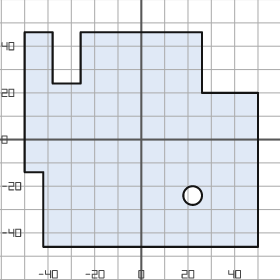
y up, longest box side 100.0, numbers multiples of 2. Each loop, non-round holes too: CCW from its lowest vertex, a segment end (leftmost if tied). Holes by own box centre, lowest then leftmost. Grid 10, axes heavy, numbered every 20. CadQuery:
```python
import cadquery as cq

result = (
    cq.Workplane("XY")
    .moveTo(-42.0, -46.0)
    .lineTo(50.0, -46.0)
    .lineTo(50.0, 20.0)
    .lineTo(26.0, 20.0)
    .lineTo(26.0, 46.0)
    .lineTo(-26.0, 46.0)
    .lineTo(-26.0, 24.0)
    .lineTo(-38.0, 24.0)
    .lineTo(-38.0, 46.0)
    .lineTo(-50.0, 46.0)
    .lineTo(-50.0, -14.0)
    .lineTo(-42.0, -14.0)
    .close()
    .moveTo(22.0, -24.0)
    .circle(4.0)
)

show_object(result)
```